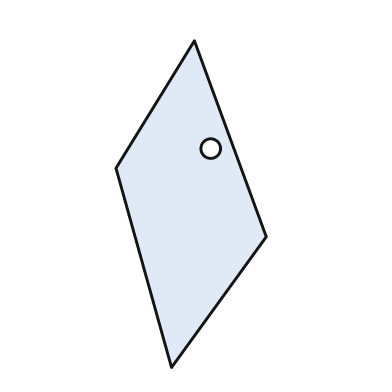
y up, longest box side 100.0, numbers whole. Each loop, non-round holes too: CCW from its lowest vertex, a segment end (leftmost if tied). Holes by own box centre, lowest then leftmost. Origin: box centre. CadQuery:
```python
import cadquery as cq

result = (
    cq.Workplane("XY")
    .moveTo(-6.0, -50.0)
    .lineTo(23.0, -10.0)
    .lineTo(1.0, 50.0)
    .lineTo(-23.0, 11.0)
    .close()
    .moveTo(6.0, 17.0)
    .circle(3.0)
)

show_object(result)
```